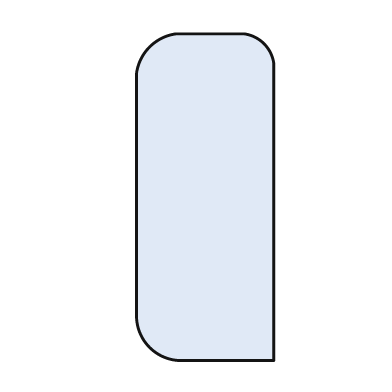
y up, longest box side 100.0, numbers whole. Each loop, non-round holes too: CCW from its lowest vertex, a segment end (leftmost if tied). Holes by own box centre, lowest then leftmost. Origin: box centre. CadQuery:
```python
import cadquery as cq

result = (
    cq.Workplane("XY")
    .moveTo(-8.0, -50.0)
    .lineTo(21.0, -50.0)
    .lineTo(21.0, 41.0)
    .threePointArc((18.0, 47.0), (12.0, 50.0))
    .lineTo(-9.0, 50.0)
    .threePointArc((-17.0, 46.0), (-21.0, 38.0))
    .lineTo(-21.0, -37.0)
    .threePointArc((-17.0, -46.0), (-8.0, -50.0))
    .close()
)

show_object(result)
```